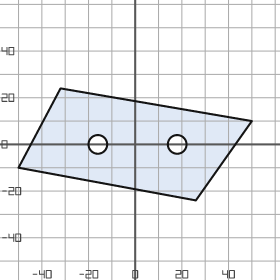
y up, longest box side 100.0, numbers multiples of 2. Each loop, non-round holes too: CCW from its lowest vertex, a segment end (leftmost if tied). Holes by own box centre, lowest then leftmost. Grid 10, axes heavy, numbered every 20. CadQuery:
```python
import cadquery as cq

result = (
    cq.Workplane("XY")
    .moveTo(26.0, -24.0)
    .lineTo(50.0, 10.0)
    .lineTo(-32.0, 24.0)
    .lineTo(-50.0, -10.0)
    .close()
    .moveTo(-16.0, 0.0)
    .circle(4.0)
    .moveTo(18.0, 0.0)
    .circle(4.0)
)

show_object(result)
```